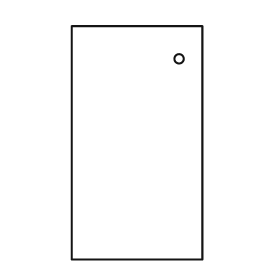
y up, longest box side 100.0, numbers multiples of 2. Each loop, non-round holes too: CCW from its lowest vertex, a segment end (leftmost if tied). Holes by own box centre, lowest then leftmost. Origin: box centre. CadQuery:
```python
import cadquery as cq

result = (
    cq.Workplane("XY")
    .moveTo(-28.0, -50.0)
    .lineTo(28.0, -50.0)
    .lineTo(28.0, 50.0)
    .lineTo(-28.0, 50.0)
    .close()
    .moveTo(18.0, 36.0)
    .circle(2.0)
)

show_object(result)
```